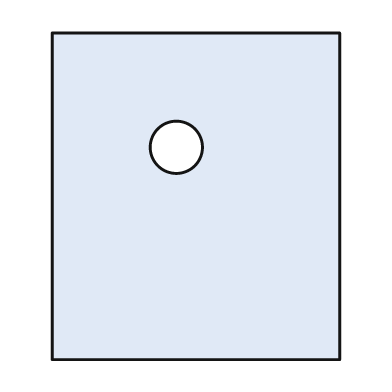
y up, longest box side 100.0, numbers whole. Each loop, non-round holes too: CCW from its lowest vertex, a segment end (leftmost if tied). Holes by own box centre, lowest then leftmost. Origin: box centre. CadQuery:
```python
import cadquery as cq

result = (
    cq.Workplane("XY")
    .moveTo(-44.0, -50.0)
    .lineTo(44.0, -50.0)
    .lineTo(44.0, 50.0)
    .lineTo(-44.0, 50.0)
    .close()
    .moveTo(-6.0, 15.0)
    .circle(8.0)
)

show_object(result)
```